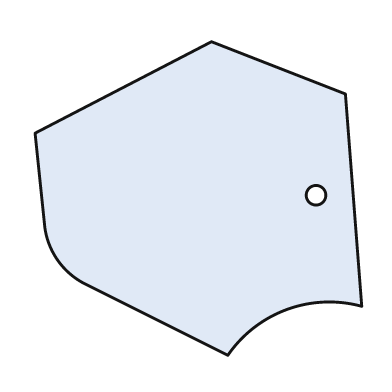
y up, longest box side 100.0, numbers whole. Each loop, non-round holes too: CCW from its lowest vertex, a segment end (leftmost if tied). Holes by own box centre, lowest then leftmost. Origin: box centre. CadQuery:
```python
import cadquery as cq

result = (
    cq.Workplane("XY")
    .moveTo(9.0, -48.0)
    .threePointArc((27.0, -34.0), (50.0, -33.0))
    .lineTo(45.0, 32.0)
    .lineTo(4.0, 48.0)
    .lineTo(-50.0, 20.0)
    .lineTo(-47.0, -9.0)
    .threePointArc((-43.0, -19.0), (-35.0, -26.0))
    .close()
    .moveTo(36.0, 1.0)
    .circle(3.0)
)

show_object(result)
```